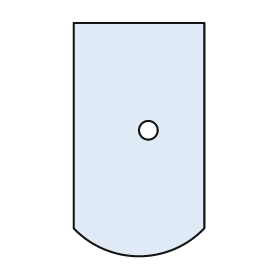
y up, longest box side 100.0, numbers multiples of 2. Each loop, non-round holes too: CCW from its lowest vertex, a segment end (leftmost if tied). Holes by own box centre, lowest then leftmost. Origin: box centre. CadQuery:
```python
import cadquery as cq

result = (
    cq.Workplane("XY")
    .moveTo(-28.0, -38.0)
    .threePointArc((0.0, -50.0), (28.0, -38.0))
    .lineTo(28.0, 50.0)
    .lineTo(-28.0, 50.0)
    .close()
    .moveTo(4.0, 4.0)
    .circle(4.0)
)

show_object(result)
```